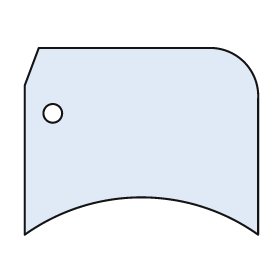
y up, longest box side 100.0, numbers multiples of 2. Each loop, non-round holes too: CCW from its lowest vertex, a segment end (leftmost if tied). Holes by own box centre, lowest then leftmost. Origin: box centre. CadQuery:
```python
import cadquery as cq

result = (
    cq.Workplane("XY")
    .moveTo(-50.0, -40.0)
    .threePointArc((0.0, -24.0), (50.0, -40.0))
    .lineTo(50.0, 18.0)
    .threePointArc((44.0, 34.0), (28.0, 40.0))
    .lineTo(-44.0, 40.0)
    .lineTo(-50.0, 24.0)
    .close()
    .moveTo(-38.0, 12.0)
    .circle(4.0)
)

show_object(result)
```